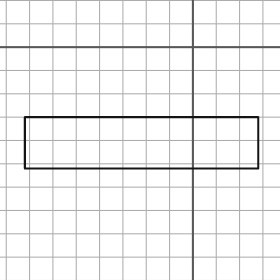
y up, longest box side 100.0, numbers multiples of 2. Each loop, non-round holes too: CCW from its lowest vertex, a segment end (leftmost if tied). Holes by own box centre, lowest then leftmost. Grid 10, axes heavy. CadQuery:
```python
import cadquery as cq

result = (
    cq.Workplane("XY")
    .moveTo(-72.0, -52.0)
    .lineTo(28.0, -52.0)
    .lineTo(28.0, -30.0)
    .lineTo(-72.0, -30.0)
    .close()
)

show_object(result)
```